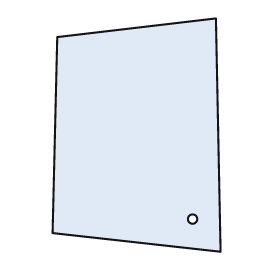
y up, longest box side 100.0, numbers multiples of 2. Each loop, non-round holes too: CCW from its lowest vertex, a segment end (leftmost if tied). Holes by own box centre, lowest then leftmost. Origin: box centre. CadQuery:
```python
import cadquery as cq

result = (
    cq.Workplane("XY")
    .moveTo(36.0, -50.0)
    .lineTo(34.0, 50.0)
    .lineTo(-34.0, 42.0)
    .lineTo(-36.0, -42.0)
    .close()
    .moveTo(24.0, -36.0)
    .circle(2.0)
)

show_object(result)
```